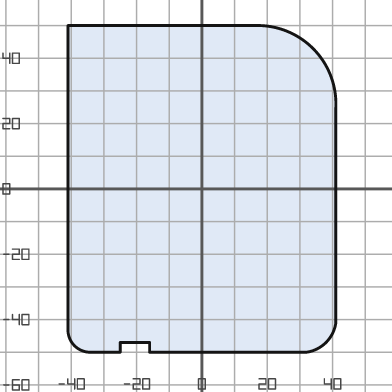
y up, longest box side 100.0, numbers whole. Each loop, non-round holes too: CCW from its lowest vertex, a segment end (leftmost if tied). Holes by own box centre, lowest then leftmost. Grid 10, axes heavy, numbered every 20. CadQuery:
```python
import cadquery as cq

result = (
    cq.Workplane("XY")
    .moveTo(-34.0, -50.0)
    .lineTo(-25.0, -50.0)
    .lineTo(-25.0, -47.0)
    .lineTo(-16.0, -47.0)
    .lineTo(-16.0, -50.0)
    .lineTo(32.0, -50.0)
    .threePointArc((38.0, -47.0), (41.0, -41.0))
    .lineTo(41.0, 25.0)
    .threePointArc((34.0, 43.0), (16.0, 50.0))
    .lineTo(-41.0, 50.0)
    .lineTo(-41.0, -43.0)
    .threePointArc((-39.0, -48.0), (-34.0, -50.0))
    .close()
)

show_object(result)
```